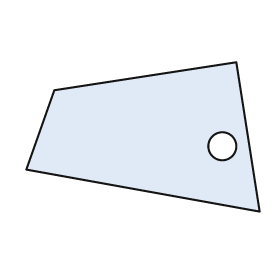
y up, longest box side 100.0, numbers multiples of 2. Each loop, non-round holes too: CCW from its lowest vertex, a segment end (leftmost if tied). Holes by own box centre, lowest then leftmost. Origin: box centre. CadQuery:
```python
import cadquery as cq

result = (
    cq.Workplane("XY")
    .moveTo(50.0, -32.0)
    .lineTo(40.0, 32.0)
    .lineTo(-38.0, 20.0)
    .lineTo(-50.0, -14.0)
    .close()
    .moveTo(34.0, -4.0)
    .circle(6.0)
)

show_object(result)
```